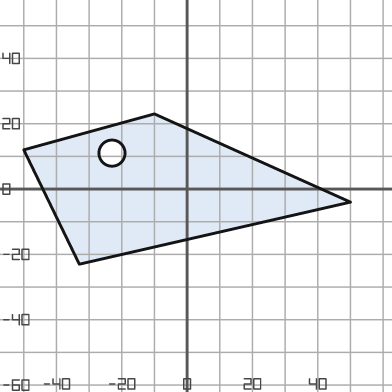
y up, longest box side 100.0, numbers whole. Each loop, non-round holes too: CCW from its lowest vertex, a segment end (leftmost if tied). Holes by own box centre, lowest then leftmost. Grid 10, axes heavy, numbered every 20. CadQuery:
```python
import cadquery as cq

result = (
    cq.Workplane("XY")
    .moveTo(-33.0, -23.0)
    .lineTo(50.0, -4.0)
    .lineTo(-10.0, 23.0)
    .lineTo(-50.0, 12.0)
    .close()
    .moveTo(-23.0, 11.0)
    .circle(4.0)
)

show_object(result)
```